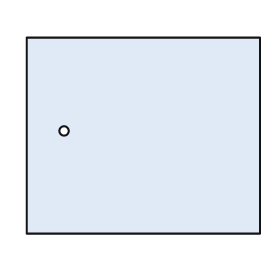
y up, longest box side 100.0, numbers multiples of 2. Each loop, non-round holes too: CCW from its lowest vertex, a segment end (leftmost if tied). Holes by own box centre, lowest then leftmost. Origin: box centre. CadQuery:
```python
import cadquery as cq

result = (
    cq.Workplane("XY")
    .moveTo(-50.0, -42.0)
    .lineTo(50.0, -42.0)
    .lineTo(50.0, 42.0)
    .lineTo(-50.0, 42.0)
    .close()
    .moveTo(-34.0, 2.0)
    .circle(2.0)
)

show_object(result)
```